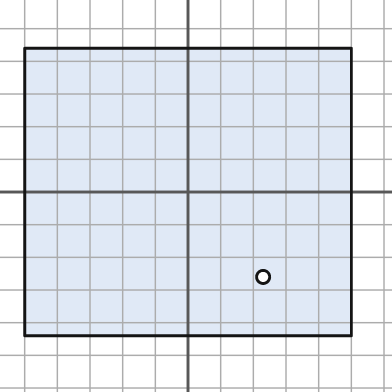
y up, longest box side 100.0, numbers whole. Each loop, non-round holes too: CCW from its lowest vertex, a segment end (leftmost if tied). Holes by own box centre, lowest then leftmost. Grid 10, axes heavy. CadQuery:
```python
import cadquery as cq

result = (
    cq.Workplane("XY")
    .moveTo(-50.0, -44.0)
    .lineTo(50.0, -44.0)
    .lineTo(50.0, 44.0)
    .lineTo(-50.0, 44.0)
    .close()
    .moveTo(23.0, -26.0)
    .circle(2.0)
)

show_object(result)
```